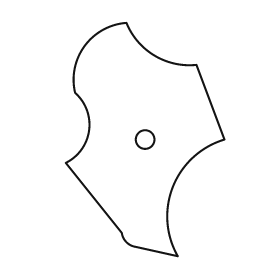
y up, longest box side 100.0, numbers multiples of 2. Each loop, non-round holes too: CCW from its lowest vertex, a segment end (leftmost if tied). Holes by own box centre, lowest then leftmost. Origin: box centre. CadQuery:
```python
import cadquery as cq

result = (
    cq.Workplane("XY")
    .moveTo(14.0, -50.0)
    .threePointArc((12.0, -20.0), (34.0, 0.0))
    .lineTo(22.0, 32.0)
    .threePointArc((4.0, 36.0), (-8.0, 50.0))
    .threePointArc((-26.0, 40.0), (-30.0, 20.0))
    .threePointArc((-24.0, 4.0), (-34.0, -10.0))
    .lineTo(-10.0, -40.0)
    .threePointArc((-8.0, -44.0), (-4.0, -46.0))
    .close()
    .moveTo(0.0, 0.0)
    .circle(4.0)
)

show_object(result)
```